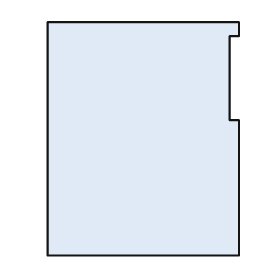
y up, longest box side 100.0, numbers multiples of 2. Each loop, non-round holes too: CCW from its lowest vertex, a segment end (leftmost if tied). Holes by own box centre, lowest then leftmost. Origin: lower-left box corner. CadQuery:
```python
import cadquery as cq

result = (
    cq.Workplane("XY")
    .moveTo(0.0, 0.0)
    .lineTo(82.0, 0.0)
    .lineTo(82.0, 58.0)
    .lineTo(78.0, 58.0)
    .lineTo(78.0, 94.0)
    .lineTo(82.0, 94.0)
    .lineTo(82.0, 100.0)
    .lineTo(0.0, 100.0)
    .close()
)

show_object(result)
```